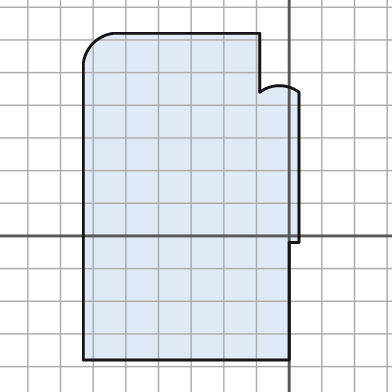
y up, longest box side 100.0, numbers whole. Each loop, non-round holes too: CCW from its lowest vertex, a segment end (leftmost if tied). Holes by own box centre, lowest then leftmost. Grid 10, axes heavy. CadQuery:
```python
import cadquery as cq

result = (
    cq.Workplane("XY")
    .moveTo(-63.0, -38.0)
    .lineTo(0.0, -38.0)
    .lineTo(0.0, -2.0)
    .lineTo(3.0, -2.0)
    .lineTo(3.0, 44.0)
    .threePointArc((-3.0, 46.0), (-9.0, 44.0))
    .lineTo(-9.0, 62.0)
    .lineTo(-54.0, 62.0)
    .threePointArc((-60.0, 59.0), (-63.0, 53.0))
    .close()
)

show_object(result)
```